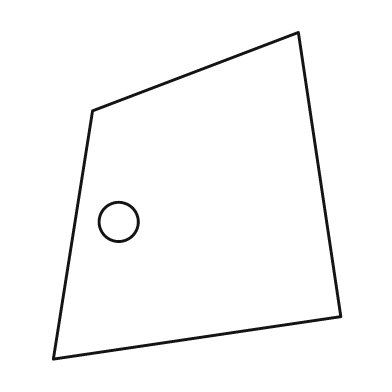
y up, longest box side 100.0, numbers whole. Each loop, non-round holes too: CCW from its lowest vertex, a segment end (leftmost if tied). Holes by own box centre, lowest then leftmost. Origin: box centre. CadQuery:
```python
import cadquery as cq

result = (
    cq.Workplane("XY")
    .moveTo(-44.0, -50.0)
    .lineTo(44.0, -37.0)
    .lineTo(31.0, 50.0)
    .lineTo(-32.0, 26.0)
    .close()
    .moveTo(-24.0, -8.0)
    .circle(6.0)
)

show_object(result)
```